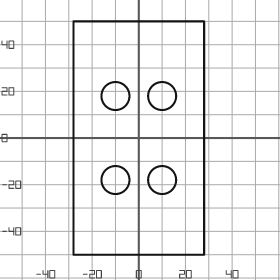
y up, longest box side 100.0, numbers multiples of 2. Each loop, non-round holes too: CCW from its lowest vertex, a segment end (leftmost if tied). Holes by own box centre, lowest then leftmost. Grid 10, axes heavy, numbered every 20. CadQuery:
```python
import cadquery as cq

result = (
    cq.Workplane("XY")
    .moveTo(-28.0, -50.0)
    .lineTo(28.0, -50.0)
    .lineTo(28.0, 50.0)
    .lineTo(-28.0, 50.0)
    .close()
    .moveTo(-10.0, -18.0)
    .circle(6.0)
    .moveTo(10.0, -18.0)
    .circle(6.0)
    .moveTo(-10.0, 18.0)
    .circle(6.0)
    .moveTo(10.0, 18.0)
    .circle(6.0)
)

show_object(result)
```